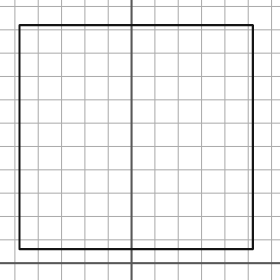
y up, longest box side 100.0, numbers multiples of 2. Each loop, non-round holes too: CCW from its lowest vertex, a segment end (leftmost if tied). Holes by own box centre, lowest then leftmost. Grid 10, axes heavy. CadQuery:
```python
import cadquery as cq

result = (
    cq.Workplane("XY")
    .moveTo(-48.0, 6.0)
    .lineTo(52.0, 6.0)
    .lineTo(52.0, 102.0)
    .lineTo(-48.0, 102.0)
    .close()
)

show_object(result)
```